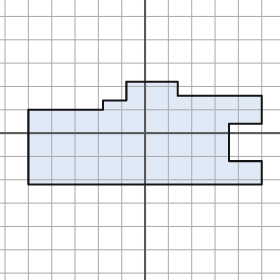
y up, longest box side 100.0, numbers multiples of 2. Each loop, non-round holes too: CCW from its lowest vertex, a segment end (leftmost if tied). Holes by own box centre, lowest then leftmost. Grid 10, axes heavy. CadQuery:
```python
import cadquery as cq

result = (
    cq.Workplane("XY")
    .moveTo(-50.0, -22.0)
    .lineTo(50.0, -22.0)
    .lineTo(50.0, -12.0)
    .lineTo(36.0, -12.0)
    .lineTo(36.0, 4.0)
    .lineTo(50.0, 4.0)
    .lineTo(50.0, 16.0)
    .lineTo(14.0, 16.0)
    .lineTo(14.0, 22.0)
    .lineTo(-8.0, 22.0)
    .lineTo(-8.0, 14.0)
    .lineTo(-18.0, 14.0)
    .lineTo(-18.0, 10.0)
    .lineTo(-50.0, 10.0)
    .close()
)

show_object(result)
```